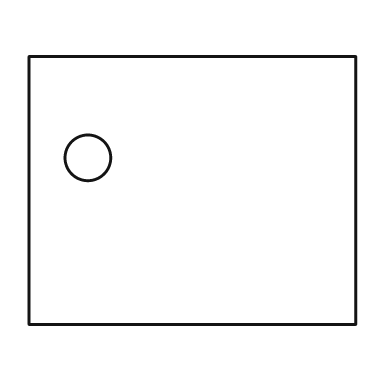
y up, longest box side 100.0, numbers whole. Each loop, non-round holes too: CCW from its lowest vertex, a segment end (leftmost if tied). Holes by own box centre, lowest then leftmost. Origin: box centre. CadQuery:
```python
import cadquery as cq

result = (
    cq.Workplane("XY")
    .moveTo(-50.0, -41.0)
    .lineTo(50.0, -41.0)
    .lineTo(50.0, 41.0)
    .lineTo(-50.0, 41.0)
    .close()
    .moveTo(-32.0, 10.0)
    .circle(7.0)
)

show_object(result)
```